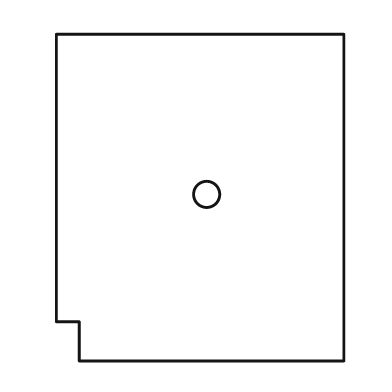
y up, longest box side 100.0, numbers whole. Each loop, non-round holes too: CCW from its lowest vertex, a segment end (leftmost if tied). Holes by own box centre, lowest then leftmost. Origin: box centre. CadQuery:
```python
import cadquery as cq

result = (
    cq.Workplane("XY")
    .moveTo(-37.0, -50.0)
    .lineTo(44.0, -50.0)
    .lineTo(44.0, 50.0)
    .lineTo(-44.0, 50.0)
    .lineTo(-44.0, -38.0)
    .lineTo(-37.0, -38.0)
    .close()
    .moveTo(2.0, 1.0)
    .circle(4.0)
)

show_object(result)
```